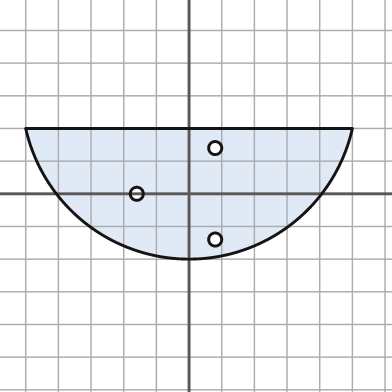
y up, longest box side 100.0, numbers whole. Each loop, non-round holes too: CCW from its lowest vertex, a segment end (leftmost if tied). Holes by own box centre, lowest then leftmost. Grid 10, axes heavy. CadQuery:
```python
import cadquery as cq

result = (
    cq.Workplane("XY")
    .moveTo(-50.0, 20.0)
    .threePointArc((0.0, -20.0), (50.0, 20.0))
    .close()
    .moveTo(8.0, -14.0)
    .circle(2.0)
    .moveTo(-16.0, 0.0)
    .circle(2.0)
    .moveTo(8.0, 14.0)
    .circle(2.0)
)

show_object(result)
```